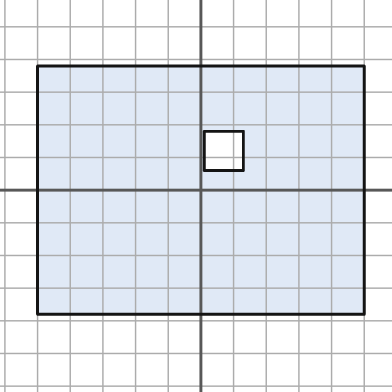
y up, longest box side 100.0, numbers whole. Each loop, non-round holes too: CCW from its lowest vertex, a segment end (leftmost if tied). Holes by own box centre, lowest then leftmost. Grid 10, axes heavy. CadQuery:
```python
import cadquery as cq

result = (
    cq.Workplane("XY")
    .moveTo(-50.0, -38.0)
    .lineTo(50.0, -38.0)
    .lineTo(50.0, 38.0)
    .lineTo(-50.0, 38.0)
    .close()
    .moveTo(1.0, 6.0)
    .lineTo(13.0, 6.0)
    .lineTo(13.0, 18.0)
    .lineTo(1.0, 18.0)
    .close()
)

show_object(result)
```